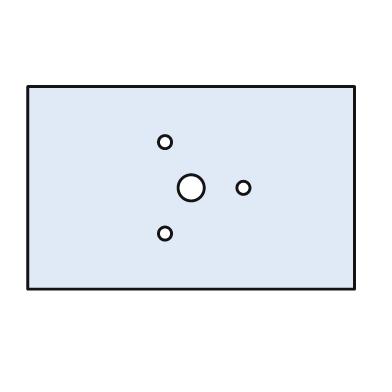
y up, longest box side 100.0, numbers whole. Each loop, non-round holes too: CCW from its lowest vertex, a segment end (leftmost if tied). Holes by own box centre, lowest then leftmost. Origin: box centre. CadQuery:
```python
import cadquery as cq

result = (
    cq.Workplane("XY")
    .moveTo(-50.0, -31.0)
    .lineTo(50.0, -31.0)
    .lineTo(50.0, 31.0)
    .lineTo(-50.0, 31.0)
    .close()
    .moveTo(-8.0, -14.0)
    .circle(2.0)
    .moveTo(0.0, 0.0)
    .circle(4.0)
    .moveTo(16.0, 0.0)
    .circle(2.0)
    .moveTo(-8.0, 14.0)
    .circle(2.0)
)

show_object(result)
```